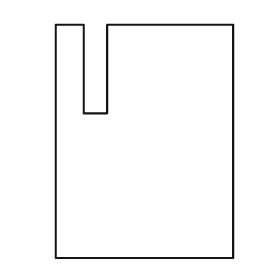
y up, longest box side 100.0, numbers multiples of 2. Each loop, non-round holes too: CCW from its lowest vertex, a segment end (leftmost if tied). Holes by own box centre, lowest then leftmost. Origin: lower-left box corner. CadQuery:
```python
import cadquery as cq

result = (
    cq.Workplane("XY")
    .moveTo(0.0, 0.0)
    .lineTo(76.0, 0.0)
    .lineTo(76.0, 100.0)
    .lineTo(22.0, 100.0)
    .lineTo(22.0, 62.0)
    .lineTo(12.0, 62.0)
    .lineTo(12.0, 100.0)
    .lineTo(0.0, 100.0)
    .close()
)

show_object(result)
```